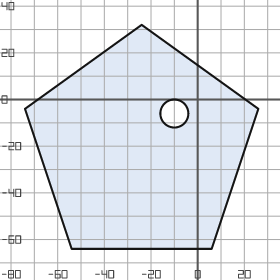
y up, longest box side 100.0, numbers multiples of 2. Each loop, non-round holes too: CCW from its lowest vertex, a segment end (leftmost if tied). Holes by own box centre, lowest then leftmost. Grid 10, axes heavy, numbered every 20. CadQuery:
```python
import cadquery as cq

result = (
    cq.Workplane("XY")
    .moveTo(-54.0, -64.0)
    .lineTo(6.0, -64.0)
    .lineTo(26.0, -4.0)
    .lineTo(-24.0, 32.0)
    .lineTo(-74.0, -4.0)
    .close()
    .moveTo(-10.0, -6.0)
    .circle(6.0)
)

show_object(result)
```